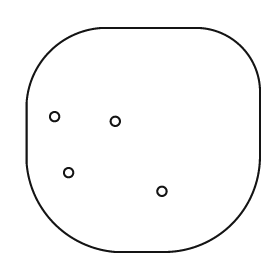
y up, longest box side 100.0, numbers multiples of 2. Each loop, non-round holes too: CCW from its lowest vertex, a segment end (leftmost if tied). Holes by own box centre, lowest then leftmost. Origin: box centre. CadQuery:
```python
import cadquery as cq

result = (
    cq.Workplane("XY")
    .moveTo(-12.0, -48.0)
    .lineTo(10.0, -48.0)
    .threePointArc((38.0, -36.0), (50.0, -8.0))
    .lineTo(50.0, 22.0)
    .threePointArc((42.0, 40.0), (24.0, 48.0))
    .lineTo(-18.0, 48.0)
    .threePointArc((-40.0, 38.0), (-50.0, 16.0))
    .lineTo(-50.0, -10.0)
    .threePointArc((-38.0, -36.0), (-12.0, -48.0))
    .close()
    .moveTo(8.0, -22.0)
    .circle(2.0)
    .moveTo(-32.0, -14.0)
    .circle(2.0)
    .moveTo(-12.0, 8.0)
    .circle(2.0)
    .moveTo(-38.0, 10.0)
    .circle(2.0)
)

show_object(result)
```